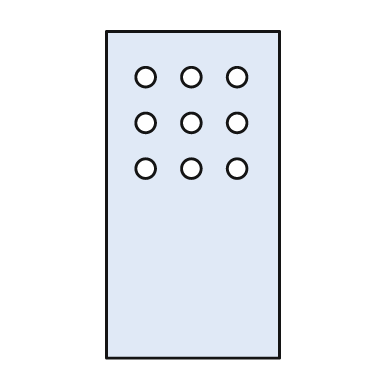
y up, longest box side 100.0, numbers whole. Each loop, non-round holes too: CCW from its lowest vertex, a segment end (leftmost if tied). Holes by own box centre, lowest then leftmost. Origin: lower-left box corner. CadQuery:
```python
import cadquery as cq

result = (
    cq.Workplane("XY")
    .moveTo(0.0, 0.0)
    .lineTo(53.0, 0.0)
    .lineTo(53.0, 100.0)
    .lineTo(0.0, 100.0)
    .close()
    .moveTo(12.0, 58.0)
    .circle(3.0)
    .moveTo(26.0, 58.0)
    .circle(3.0)
    .moveTo(40.0, 58.0)
    .circle(3.0)
    .moveTo(12.0, 72.0)
    .circle(3.0)
    .moveTo(26.0, 72.0)
    .circle(3.0)
    .moveTo(40.0, 72.0)
    .circle(3.0)
    .moveTo(12.0, 86.0)
    .circle(3.0)
    .moveTo(26.0, 86.0)
    .circle(3.0)
    .moveTo(40.0, 86.0)
    .circle(3.0)
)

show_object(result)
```